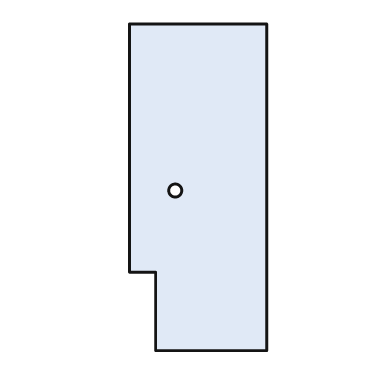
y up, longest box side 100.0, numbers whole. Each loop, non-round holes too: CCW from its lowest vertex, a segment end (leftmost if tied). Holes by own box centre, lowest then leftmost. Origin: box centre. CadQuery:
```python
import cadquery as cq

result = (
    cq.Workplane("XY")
    .moveTo(-13.0, -50.0)
    .lineTo(21.0, -50.0)
    .lineTo(21.0, 50.0)
    .lineTo(-21.0, 50.0)
    .lineTo(-21.0, -26.0)
    .lineTo(-13.0, -26.0)
    .close()
    .moveTo(-7.0, -1.0)
    .circle(2.0)
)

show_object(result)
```